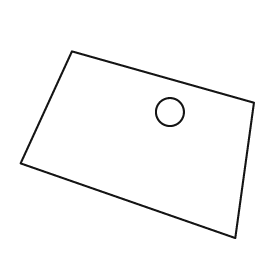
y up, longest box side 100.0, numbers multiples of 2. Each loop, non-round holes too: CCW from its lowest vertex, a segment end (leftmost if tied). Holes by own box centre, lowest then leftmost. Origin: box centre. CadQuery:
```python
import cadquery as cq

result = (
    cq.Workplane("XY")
    .moveTo(42.0, -40.0)
    .lineTo(50.0, 18.0)
    .lineTo(-28.0, 40.0)
    .lineTo(-50.0, -8.0)
    .close()
    .moveTo(14.0, 14.0)
    .circle(6.0)
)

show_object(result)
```